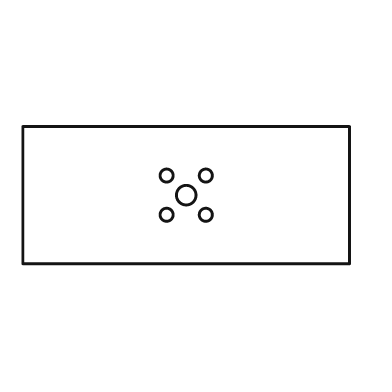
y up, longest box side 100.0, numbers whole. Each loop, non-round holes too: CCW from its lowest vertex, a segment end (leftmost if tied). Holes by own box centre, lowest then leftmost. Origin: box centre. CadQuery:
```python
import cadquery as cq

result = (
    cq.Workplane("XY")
    .moveTo(-50.0, -21.0)
    .lineTo(50.0, -21.0)
    .lineTo(50.0, 21.0)
    .lineTo(-50.0, 21.0)
    .close()
    .moveTo(-6.0, -6.0)
    .circle(2.0)
    .moveTo(6.0, -6.0)
    .circle(2.0)
    .moveTo(0.0, 0.0)
    .circle(3.0)
    .moveTo(-6.0, 6.0)
    .circle(2.0)
    .moveTo(6.0, 6.0)
    .circle(2.0)
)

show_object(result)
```